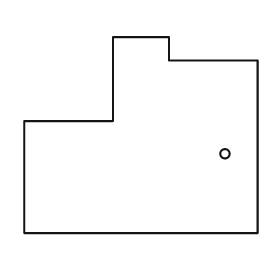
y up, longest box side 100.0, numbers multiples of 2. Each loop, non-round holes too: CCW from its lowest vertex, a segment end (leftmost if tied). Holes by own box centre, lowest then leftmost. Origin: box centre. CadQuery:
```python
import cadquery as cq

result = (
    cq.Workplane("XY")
    .moveTo(-50.0, -42.0)
    .lineTo(50.0, -42.0)
    .lineTo(50.0, 32.0)
    .lineTo(12.0, 32.0)
    .lineTo(12.0, 42.0)
    .lineTo(-12.0, 42.0)
    .lineTo(-12.0, 6.0)
    .lineTo(-50.0, 6.0)
    .close()
    .moveTo(36.0, -8.0)
    .circle(2.0)
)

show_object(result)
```